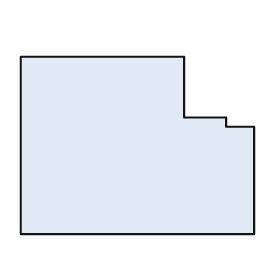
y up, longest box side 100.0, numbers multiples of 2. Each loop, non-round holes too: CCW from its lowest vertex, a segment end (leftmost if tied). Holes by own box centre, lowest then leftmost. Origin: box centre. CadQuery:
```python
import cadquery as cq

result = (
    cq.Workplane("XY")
    .moveTo(-50.0, -38.0)
    .lineTo(50.0, -38.0)
    .lineTo(50.0, 8.0)
    .lineTo(38.0, 8.0)
    .lineTo(38.0, 12.0)
    .lineTo(20.0, 12.0)
    .lineTo(20.0, 38.0)
    .lineTo(-50.0, 38.0)
    .close()
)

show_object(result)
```